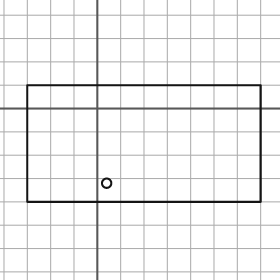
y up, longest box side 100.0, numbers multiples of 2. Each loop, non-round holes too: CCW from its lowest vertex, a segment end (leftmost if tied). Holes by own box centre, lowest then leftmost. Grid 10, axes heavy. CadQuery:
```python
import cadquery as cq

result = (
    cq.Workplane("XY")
    .moveTo(-30.0, -40.0)
    .lineTo(70.0, -40.0)
    .lineTo(70.0, 10.0)
    .lineTo(-30.0, 10.0)
    .close()
    .moveTo(4.0, -32.0)
    .circle(2.0)
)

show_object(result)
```